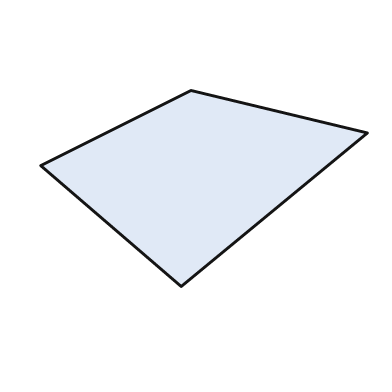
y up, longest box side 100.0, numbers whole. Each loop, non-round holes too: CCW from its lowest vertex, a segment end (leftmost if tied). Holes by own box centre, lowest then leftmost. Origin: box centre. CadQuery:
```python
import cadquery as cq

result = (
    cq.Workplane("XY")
    .moveTo(-7.0, -30.0)
    .lineTo(50.0, 17.0)
    .lineTo(-4.0, 30.0)
    .lineTo(-50.0, 7.0)
    .close()
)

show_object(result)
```